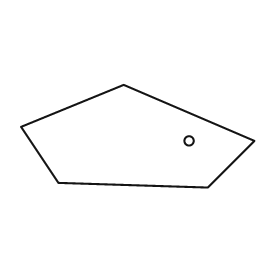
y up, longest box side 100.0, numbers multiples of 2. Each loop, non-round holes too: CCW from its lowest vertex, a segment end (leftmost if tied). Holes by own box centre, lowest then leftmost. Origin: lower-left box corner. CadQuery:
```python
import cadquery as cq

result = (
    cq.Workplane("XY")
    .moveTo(80.0, 0.0)
    .lineTo(100.0, 20.0)
    .lineTo(44.0, 44.0)
    .lineTo(0.0, 26.0)
    .lineTo(16.0, 2.0)
    .close()
    .moveTo(72.0, 20.0)
    .circle(2.0)
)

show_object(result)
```